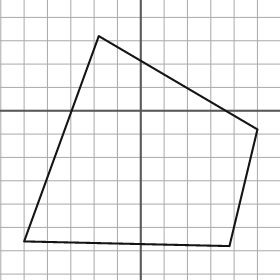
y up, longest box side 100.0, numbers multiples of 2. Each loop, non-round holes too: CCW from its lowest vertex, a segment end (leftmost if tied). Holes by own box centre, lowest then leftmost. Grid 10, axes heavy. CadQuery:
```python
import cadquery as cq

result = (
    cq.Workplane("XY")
    .moveTo(38.0, -58.0)
    .lineTo(50.0, -8.0)
    .lineTo(-18.0, 32.0)
    .lineTo(-50.0, -56.0)
    .close()
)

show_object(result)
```